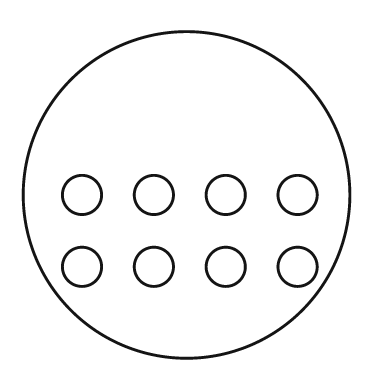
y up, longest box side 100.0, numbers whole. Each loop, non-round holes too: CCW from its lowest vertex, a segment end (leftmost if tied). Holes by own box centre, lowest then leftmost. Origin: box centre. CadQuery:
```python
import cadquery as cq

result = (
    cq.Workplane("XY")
    .moveTo(0.0, 0.0)
    .circle(50.0)
    .moveTo(-32.0, -22.0)
    .circle(6.0)
    .moveTo(-10.0, -22.0)
    .circle(6.0)
    .moveTo(12.0, -22.0)
    .circle(6.0)
    .moveTo(34.0, -22.0)
    .circle(6.0)
    .moveTo(-32.0, 0.0)
    .circle(6.0)
    .moveTo(-10.0, 0.0)
    .circle(6.0)
    .moveTo(12.0, 0.0)
    .circle(6.0)
    .moveTo(34.0, 0.0)
    .circle(6.0)
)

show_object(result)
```